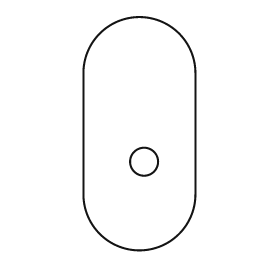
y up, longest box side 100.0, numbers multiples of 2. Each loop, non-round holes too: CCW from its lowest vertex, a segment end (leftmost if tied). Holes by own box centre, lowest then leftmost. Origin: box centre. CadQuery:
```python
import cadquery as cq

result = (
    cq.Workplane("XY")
    .moveTo(-24.0, -26.0)
    .threePointArc((0.0, -50.0), (24.0, -26.0))
    .lineTo(24.0, 26.0)
    .threePointArc((0.0, 50.0), (-24.0, 26.0))
    .close()
    .moveTo(2.0, -12.0)
    .circle(6.0)
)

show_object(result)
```